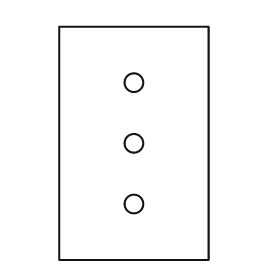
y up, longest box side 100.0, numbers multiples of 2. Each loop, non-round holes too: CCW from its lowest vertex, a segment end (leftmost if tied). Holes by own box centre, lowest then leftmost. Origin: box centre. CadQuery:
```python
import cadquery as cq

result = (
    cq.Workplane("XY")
    .moveTo(-32.0, -50.0)
    .lineTo(32.0, -50.0)
    .lineTo(32.0, 50.0)
    .lineTo(-32.0, 50.0)
    .close()
    .moveTo(0.0, -26.0)
    .circle(4.0)
    .moveTo(0.0, 0.0)
    .circle(4.0)
    .moveTo(0.0, 26.0)
    .circle(4.0)
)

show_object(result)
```